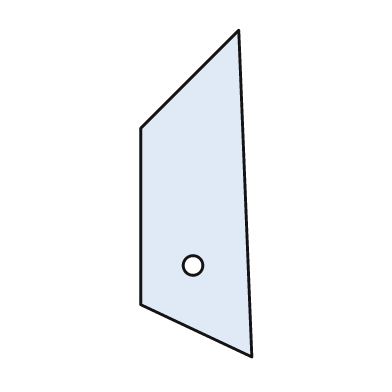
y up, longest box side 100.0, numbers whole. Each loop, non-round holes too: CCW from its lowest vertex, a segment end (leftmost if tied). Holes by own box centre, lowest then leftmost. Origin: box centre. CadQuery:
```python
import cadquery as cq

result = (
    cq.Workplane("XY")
    .moveTo(17.0, -50.0)
    .lineTo(13.0, 50.0)
    .lineTo(-17.0, 20.0)
    .lineTo(-17.0, -34.0)
    .close()
    .moveTo(-1.0, -22.0)
    .circle(3.0)
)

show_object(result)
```